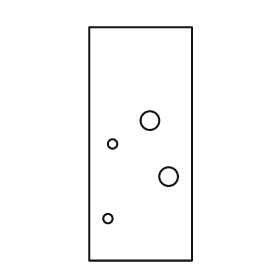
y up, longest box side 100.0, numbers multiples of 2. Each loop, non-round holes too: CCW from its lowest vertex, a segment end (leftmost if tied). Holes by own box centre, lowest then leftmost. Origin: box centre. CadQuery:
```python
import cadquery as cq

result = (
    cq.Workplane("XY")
    .moveTo(-22.0, -50.0)
    .lineTo(22.0, -50.0)
    .lineTo(22.0, 50.0)
    .lineTo(-22.0, 50.0)
    .close()
    .moveTo(-14.0, -32.0)
    .circle(2.0)
    .moveTo(12.0, -14.0)
    .circle(4.0)
    .moveTo(-12.0, 0.0)
    .circle(2.0)
    .moveTo(4.0, 10.0)
    .circle(4.0)
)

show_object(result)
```